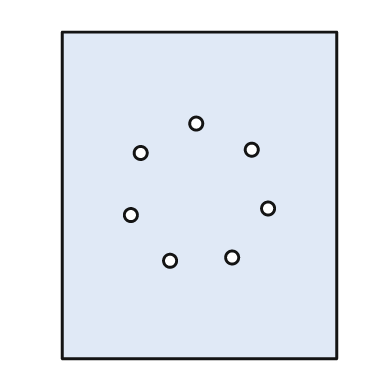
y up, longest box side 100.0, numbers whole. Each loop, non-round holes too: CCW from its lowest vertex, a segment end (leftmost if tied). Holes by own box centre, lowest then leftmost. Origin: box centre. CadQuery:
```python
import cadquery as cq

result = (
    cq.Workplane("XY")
    .moveTo(-42.0, -50.0)
    .lineTo(42.0, -50.0)
    .lineTo(42.0, 50.0)
    .lineTo(-42.0, 50.0)
    .close()
    .moveTo(-9.0, -20.0)
    .circle(2.0)
    .moveTo(10.0, -19.0)
    .circle(2.0)
    .moveTo(-21.0, -6.0)
    .circle(2.0)
    .moveTo(21.0, -4.0)
    .circle(2.0)
    .moveTo(-18.0, 13.0)
    .circle(2.0)
    .moveTo(16.0, 14.0)
    .circle(2.0)
    .moveTo(-1.0, 22.0)
    .circle(2.0)
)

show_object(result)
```